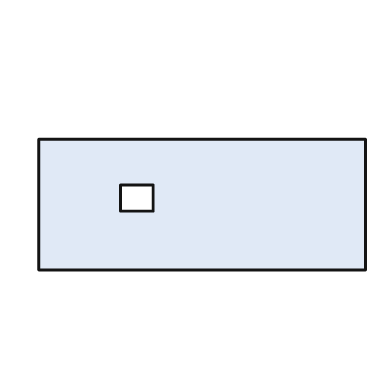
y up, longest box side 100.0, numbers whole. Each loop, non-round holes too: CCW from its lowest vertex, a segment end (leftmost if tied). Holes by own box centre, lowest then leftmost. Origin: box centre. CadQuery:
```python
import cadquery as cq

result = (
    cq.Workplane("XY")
    .moveTo(-50.0, -20.0)
    .lineTo(50.0, -20.0)
    .lineTo(50.0, 20.0)
    .lineTo(-50.0, 20.0)
    .close()
    .moveTo(-25.0, -2.0)
    .lineTo(-15.0, -2.0)
    .lineTo(-15.0, 6.0)
    .lineTo(-25.0, 6.0)
    .close()
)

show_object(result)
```